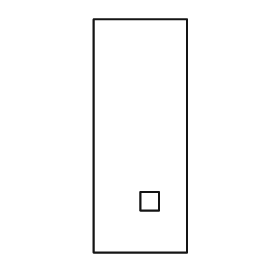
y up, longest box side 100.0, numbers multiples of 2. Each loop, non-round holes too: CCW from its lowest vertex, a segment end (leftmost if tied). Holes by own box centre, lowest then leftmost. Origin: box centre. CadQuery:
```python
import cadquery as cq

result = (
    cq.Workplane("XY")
    .moveTo(-20.0, -50.0)
    .lineTo(20.0, -50.0)
    .lineTo(20.0, 50.0)
    .lineTo(-20.0, 50.0)
    .close()
    .moveTo(0.0, -32.0)
    .lineTo(8.0, -32.0)
    .lineTo(8.0, -24.0)
    .lineTo(0.0, -24.0)
    .close()
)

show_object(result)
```